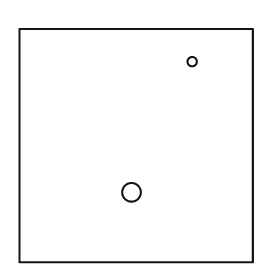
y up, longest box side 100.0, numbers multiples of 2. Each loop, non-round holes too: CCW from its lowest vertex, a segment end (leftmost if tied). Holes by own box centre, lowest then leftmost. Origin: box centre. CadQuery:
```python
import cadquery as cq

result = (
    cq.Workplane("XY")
    .moveTo(-50.0, -50.0)
    .lineTo(50.0, -50.0)
    .lineTo(50.0, 50.0)
    .lineTo(-50.0, 50.0)
    .close()
    .moveTo(-2.0, -20.0)
    .circle(4.0)
    .moveTo(24.0, 36.0)
    .circle(2.0)
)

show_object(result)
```